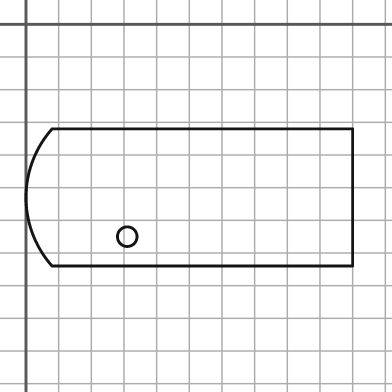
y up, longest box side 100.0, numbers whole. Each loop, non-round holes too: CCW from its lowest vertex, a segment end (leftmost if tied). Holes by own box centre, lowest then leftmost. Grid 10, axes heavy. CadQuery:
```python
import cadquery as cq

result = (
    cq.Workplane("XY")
    .moveTo(8.0, -74.0)
    .lineTo(100.0, -74.0)
    .lineTo(100.0, -32.0)
    .lineTo(8.0, -32.0)
    .threePointArc((0.0, -53.0), (8.0, -74.0))
    .close()
    .moveTo(31.0, -65.0)
    .circle(3.0)
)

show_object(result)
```